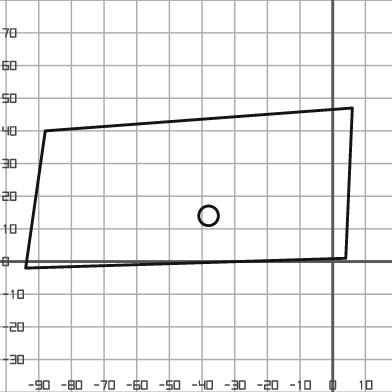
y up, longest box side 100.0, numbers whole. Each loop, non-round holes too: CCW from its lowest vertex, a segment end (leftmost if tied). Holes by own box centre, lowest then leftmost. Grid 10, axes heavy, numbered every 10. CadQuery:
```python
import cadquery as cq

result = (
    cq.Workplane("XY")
    .moveTo(-94.0, -2.0)
    .lineTo(4.0, 1.0)
    .lineTo(6.0, 47.0)
    .lineTo(-88.0, 40.0)
    .close()
    .moveTo(-38.0, 14.0)
    .circle(3.0)
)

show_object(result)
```